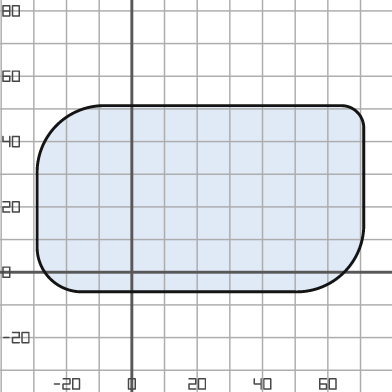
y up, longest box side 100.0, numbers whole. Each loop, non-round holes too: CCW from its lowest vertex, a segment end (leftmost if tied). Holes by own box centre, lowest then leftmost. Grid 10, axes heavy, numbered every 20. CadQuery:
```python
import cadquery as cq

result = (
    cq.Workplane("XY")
    .moveTo(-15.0, -6.0)
    .lineTo(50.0, -6.0)
    .threePointArc((65.0, 0.0), (71.0, 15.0))
    .lineTo(71.0, 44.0)
    .threePointArc((69.0, 49.0), (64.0, 51.0))
    .lineTo(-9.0, 51.0)
    .threePointArc((-23.0, 45.0), (-29.0, 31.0))
    .lineTo(-29.0, 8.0)
    .threePointArc((-25.0, -2.0), (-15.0, -6.0))
    .close()
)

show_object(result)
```